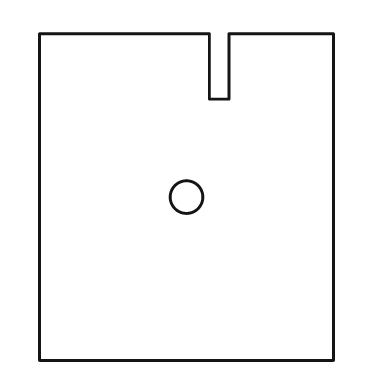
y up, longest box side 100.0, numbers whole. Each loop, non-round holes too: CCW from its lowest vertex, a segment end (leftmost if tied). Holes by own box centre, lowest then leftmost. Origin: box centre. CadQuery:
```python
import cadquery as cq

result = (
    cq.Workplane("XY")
    .moveTo(-45.0, -50.0)
    .lineTo(45.0, -50.0)
    .lineTo(45.0, 50.0)
    .lineTo(13.0, 50.0)
    .lineTo(13.0, 30.0)
    .lineTo(7.0, 30.0)
    .lineTo(7.0, 50.0)
    .lineTo(-45.0, 50.0)
    .close()
    .moveTo(0.0, 0.0)
    .circle(5.0)
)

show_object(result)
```